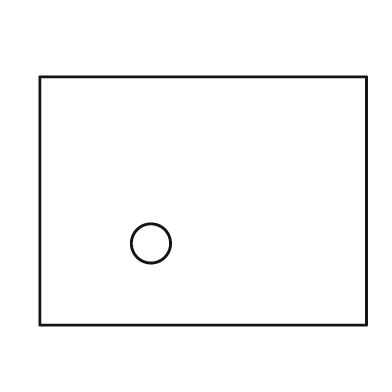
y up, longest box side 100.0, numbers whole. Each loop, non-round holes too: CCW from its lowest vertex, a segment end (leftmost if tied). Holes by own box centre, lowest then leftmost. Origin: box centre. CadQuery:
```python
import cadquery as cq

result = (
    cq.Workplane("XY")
    .moveTo(-50.0, -38.0)
    .lineTo(50.0, -38.0)
    .lineTo(50.0, 38.0)
    .lineTo(-50.0, 38.0)
    .close()
    .moveTo(-16.0, -13.0)
    .circle(6.0)
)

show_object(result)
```